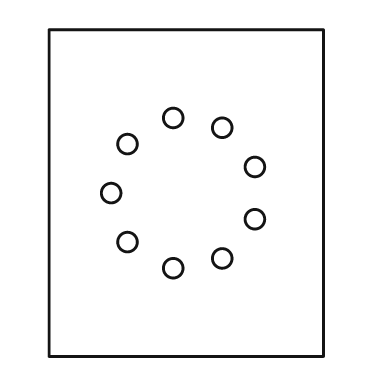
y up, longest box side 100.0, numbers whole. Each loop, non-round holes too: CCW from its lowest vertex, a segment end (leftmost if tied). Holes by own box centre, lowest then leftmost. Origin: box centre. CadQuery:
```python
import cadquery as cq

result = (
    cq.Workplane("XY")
    .moveTo(-42.0, -50.0)
    .lineTo(42.0, -50.0)
    .lineTo(42.0, 50.0)
    .lineTo(-42.0, 50.0)
    .close()
    .moveTo(-4.0, -23.0)
    .circle(3.0)
    .moveTo(11.0, -20.0)
    .circle(3.0)
    .moveTo(-18.0, -15.0)
    .circle(3.0)
    .moveTo(21.0, -8.0)
    .circle(3.0)
    .moveTo(-23.0, 0.0)
    .circle(3.0)
    .moveTo(21.0, 8.0)
    .circle(3.0)
    .moveTo(-18.0, 15.0)
    .circle(3.0)
    .moveTo(11.0, 20.0)
    .circle(3.0)
    .moveTo(-4.0, 23.0)
    .circle(3.0)
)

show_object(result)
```